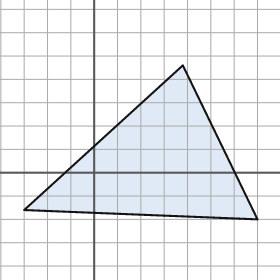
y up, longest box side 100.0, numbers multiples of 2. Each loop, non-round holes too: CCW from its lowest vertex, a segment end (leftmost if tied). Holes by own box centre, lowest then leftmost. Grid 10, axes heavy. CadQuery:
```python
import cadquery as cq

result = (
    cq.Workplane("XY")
    .moveTo(70.0, -20.0)
    .lineTo(38.0, 46.0)
    .lineTo(-30.0, -16.0)
    .close()
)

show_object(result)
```